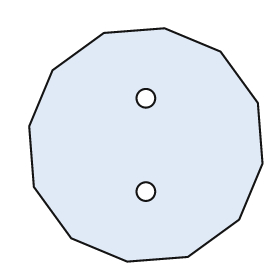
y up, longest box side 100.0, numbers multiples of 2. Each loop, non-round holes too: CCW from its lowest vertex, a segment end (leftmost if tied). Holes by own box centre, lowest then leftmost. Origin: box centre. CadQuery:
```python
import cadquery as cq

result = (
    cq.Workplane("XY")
    .moveTo(-8.0, -50.0)
    .lineTo(18.0, -48.0)
    .lineTo(40.0, -32.0)
    .lineTo(50.0, -8.0)
    .lineTo(48.0, 18.0)
    .lineTo(32.0, 40.0)
    .lineTo(8.0, 50.0)
    .lineTo(-18.0, 48.0)
    .lineTo(-40.0, 32.0)
    .lineTo(-50.0, 8.0)
    .lineTo(-48.0, -18.0)
    .lineTo(-32.0, -40.0)
    .close()
    .moveTo(0.0, -20.0)
    .circle(4.0)
    .moveTo(0.0, 20.0)
    .circle(4.0)
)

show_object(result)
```